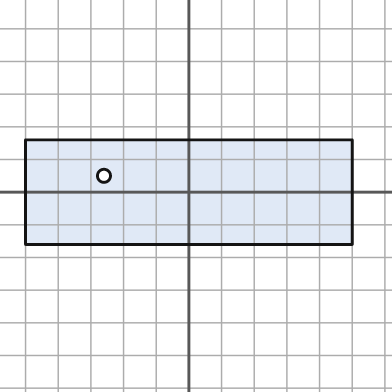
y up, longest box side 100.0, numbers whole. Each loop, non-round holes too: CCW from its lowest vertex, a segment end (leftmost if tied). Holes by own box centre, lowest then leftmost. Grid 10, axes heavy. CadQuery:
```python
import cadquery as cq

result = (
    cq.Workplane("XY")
    .moveTo(-50.0, -16.0)
    .lineTo(50.0, -16.0)
    .lineTo(50.0, 16.0)
    .lineTo(-50.0, 16.0)
    .close()
    .moveTo(-26.0, 5.0)
    .circle(2.0)
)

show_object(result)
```